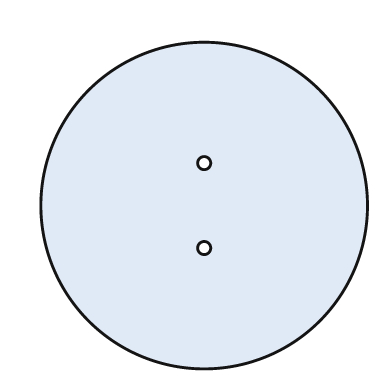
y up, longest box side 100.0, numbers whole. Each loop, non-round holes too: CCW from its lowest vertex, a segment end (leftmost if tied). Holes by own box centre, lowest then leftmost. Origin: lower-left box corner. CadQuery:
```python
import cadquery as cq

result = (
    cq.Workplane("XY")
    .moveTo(50.0, 50.0)
    .circle(50.0)
    .moveTo(50.0, 37.0)
    .circle(2.0)
    .moveTo(50.0, 63.0)
    .circle(2.0)
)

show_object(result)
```